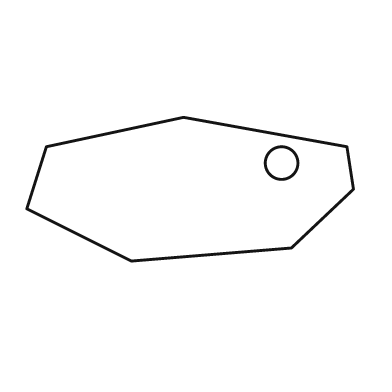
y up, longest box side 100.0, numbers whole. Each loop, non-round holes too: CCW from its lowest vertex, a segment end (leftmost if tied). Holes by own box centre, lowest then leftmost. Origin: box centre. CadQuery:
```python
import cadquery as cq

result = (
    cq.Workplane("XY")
    .moveTo(-18.0, -22.0)
    .lineTo(31.0, -18.0)
    .lineTo(50.0, 0.0)
    .lineTo(48.0, 13.0)
    .lineTo(-2.0, 22.0)
    .lineTo(-44.0, 13.0)
    .lineTo(-50.0, -6.0)
    .close()
    .moveTo(28.0, 8.0)
    .circle(5.0)
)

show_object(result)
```